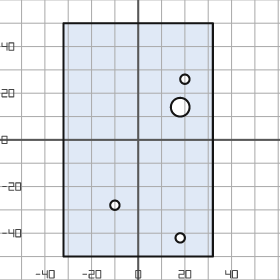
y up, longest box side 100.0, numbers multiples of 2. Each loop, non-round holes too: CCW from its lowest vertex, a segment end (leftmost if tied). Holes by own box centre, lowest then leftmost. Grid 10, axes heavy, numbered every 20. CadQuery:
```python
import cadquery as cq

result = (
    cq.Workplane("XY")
    .moveTo(-32.0, -50.0)
    .lineTo(32.0, -50.0)
    .lineTo(32.0, 50.0)
    .lineTo(-32.0, 50.0)
    .close()
    .moveTo(18.0, -42.0)
    .circle(2.0)
    .moveTo(-10.0, -28.0)
    .circle(2.0)
    .moveTo(18.0, 14.0)
    .circle(4.0)
    .moveTo(20.0, 26.0)
    .circle(2.0)
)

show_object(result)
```